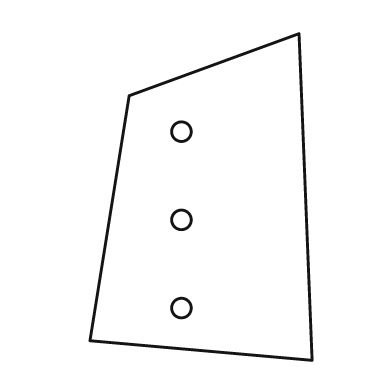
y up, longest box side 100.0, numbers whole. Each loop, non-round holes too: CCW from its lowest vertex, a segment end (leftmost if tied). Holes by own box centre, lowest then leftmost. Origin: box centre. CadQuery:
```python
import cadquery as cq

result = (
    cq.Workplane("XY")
    .moveTo(34.0, -50.0)
    .lineTo(30.0, 50.0)
    .lineTo(-22.0, 31.0)
    .lineTo(-34.0, -44.0)
    .close()
    .moveTo(-6.0, -34.0)
    .circle(3.0)
    .moveTo(-6.0, -7.0)
    .circle(3.0)
    .moveTo(-6.0, 20.0)
    .circle(3.0)
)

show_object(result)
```